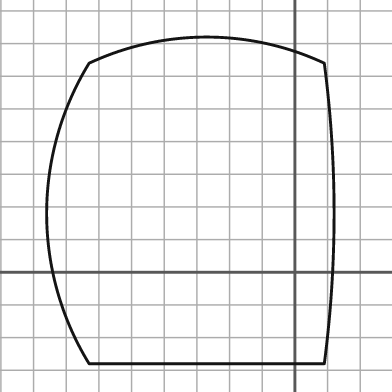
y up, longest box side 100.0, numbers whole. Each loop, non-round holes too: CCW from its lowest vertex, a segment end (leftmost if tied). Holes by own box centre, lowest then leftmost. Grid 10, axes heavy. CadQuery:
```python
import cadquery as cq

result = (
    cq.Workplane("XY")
    .moveTo(-63.0, -28.0)
    .lineTo(9.0, -28.0)
    .threePointArc((12.0, 18.0), (9.0, 64.0))
    .threePointArc((-27.0, 72.0), (-63.0, 64.0))
    .threePointArc((-76.0, 18.0), (-63.0, -28.0))
    .close()
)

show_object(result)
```